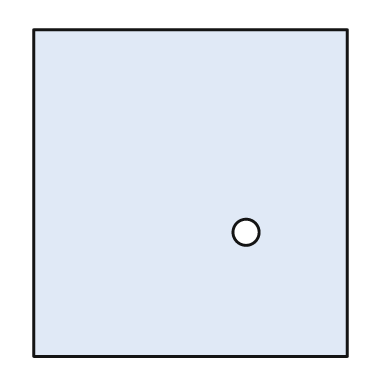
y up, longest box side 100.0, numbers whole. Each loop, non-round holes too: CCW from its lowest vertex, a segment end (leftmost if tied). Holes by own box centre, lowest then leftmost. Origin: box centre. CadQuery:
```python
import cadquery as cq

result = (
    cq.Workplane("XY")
    .moveTo(-48.0, -50.0)
    .lineTo(48.0, -50.0)
    .lineTo(48.0, 50.0)
    .lineTo(-48.0, 50.0)
    .close()
    .moveTo(17.0, -12.0)
    .circle(4.0)
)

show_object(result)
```